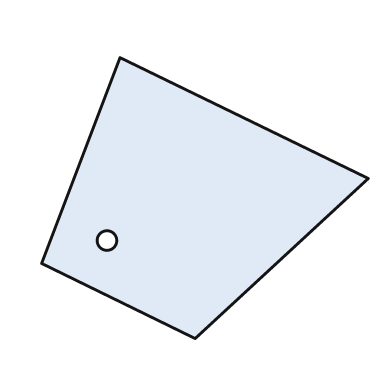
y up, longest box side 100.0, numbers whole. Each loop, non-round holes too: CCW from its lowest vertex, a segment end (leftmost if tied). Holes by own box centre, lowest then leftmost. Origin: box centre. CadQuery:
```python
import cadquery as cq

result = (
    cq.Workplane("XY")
    .moveTo(-3.0, -43.0)
    .lineTo(50.0, 6.0)
    .lineTo(-26.0, 43.0)
    .lineTo(-50.0, -20.0)
    .close()
    .moveTo(-30.0, -13.0)
    .circle(3.0)
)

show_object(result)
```